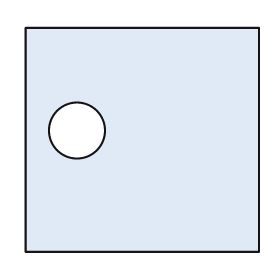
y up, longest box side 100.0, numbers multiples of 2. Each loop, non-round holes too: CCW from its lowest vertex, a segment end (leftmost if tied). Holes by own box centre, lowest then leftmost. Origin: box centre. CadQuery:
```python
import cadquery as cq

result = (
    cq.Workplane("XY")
    .moveTo(-50.0, -48.0)
    .lineTo(50.0, -48.0)
    .lineTo(50.0, 48.0)
    .lineTo(-50.0, 48.0)
    .close()
    .moveTo(-28.0, 4.0)
    .circle(12.0)
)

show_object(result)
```